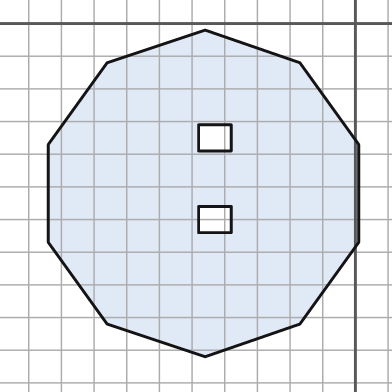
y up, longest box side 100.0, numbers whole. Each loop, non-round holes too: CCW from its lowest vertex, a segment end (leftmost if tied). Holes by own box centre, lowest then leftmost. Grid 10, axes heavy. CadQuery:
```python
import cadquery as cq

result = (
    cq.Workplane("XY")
    .moveTo(-46.0, -102.0)
    .lineTo(-17.0, -92.0)
    .lineTo(1.0, -67.0)
    .lineTo(1.0, -37.0)
    .lineTo(-17.0, -12.0)
    .lineTo(-46.0, -2.0)
    .lineTo(-76.0, -12.0)
    .lineTo(-94.0, -37.0)
    .lineTo(-94.0, -67.0)
    .lineTo(-76.0, -92.0)
    .close()
    .moveTo(-48.0, -64.0)
    .lineTo(-38.0, -64.0)
    .lineTo(-38.0, -56.0)
    .lineTo(-48.0, -56.0)
    .close()
    .moveTo(-48.0, -39.0)
    .lineTo(-38.0, -39.0)
    .lineTo(-38.0, -31.0)
    .lineTo(-48.0, -31.0)
    .close()
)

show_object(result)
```